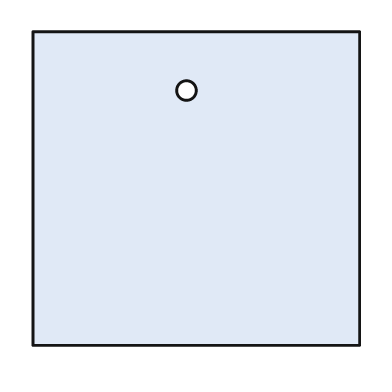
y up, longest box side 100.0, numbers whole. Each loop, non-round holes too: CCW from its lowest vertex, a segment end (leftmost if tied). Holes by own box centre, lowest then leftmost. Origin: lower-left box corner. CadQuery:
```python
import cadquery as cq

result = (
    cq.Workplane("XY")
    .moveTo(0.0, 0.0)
    .lineTo(100.0, 0.0)
    .lineTo(100.0, 96.0)
    .lineTo(0.0, 96.0)
    .close()
    .moveTo(47.0, 78.0)
    .circle(3.0)
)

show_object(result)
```